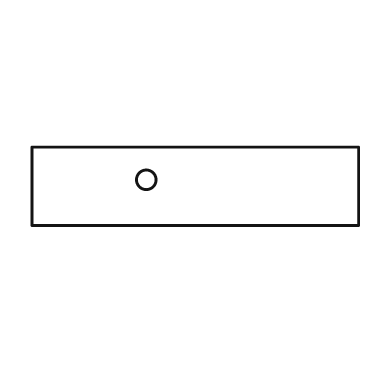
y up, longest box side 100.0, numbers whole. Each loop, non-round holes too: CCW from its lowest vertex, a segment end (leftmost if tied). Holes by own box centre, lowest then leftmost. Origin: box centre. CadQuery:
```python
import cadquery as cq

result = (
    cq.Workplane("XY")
    .moveTo(-50.0, -12.0)
    .lineTo(50.0, -12.0)
    .lineTo(50.0, 12.0)
    .lineTo(-50.0, 12.0)
    .close()
    .moveTo(-15.0, 2.0)
    .circle(3.0)
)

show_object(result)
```